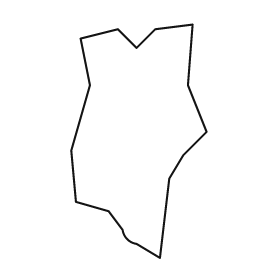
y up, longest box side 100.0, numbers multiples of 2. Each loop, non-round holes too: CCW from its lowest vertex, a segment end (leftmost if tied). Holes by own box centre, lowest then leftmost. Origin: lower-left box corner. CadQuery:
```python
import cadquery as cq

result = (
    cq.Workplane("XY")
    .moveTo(38.0, 0.0)
    .lineTo(42.0, 34.0)
    .lineTo(48.0, 44.0)
    .lineTo(58.0, 54.0)
    .lineTo(50.0, 74.0)
    .lineTo(52.0, 100.0)
    .lineTo(36.0, 98.0)
    .lineTo(28.0, 90.0)
    .lineTo(20.0, 98.0)
    .lineTo(4.0, 94.0)
    .lineTo(8.0, 74.0)
    .lineTo(0.0, 46.0)
    .lineTo(2.0, 24.0)
    .lineTo(16.0, 20.0)
    .lineTo(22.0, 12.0)
    .threePointArc((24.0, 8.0), (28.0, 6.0))
    .close()
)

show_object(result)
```